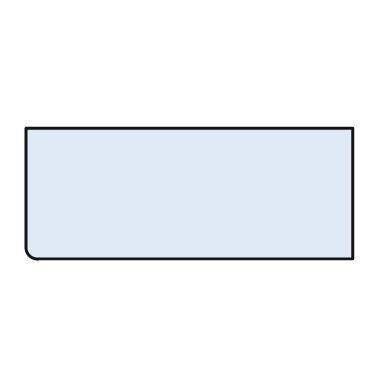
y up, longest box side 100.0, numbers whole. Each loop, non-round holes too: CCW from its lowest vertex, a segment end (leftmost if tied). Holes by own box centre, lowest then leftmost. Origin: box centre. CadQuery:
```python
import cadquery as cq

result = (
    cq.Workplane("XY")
    .moveTo(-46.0, -20.0)
    .lineTo(50.0, -20.0)
    .lineTo(50.0, 20.0)
    .lineTo(-50.0, 20.0)
    .lineTo(-50.0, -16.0)
    .threePointArc((-49.0, -19.0), (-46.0, -20.0))
    .close()
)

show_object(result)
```